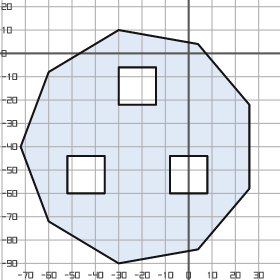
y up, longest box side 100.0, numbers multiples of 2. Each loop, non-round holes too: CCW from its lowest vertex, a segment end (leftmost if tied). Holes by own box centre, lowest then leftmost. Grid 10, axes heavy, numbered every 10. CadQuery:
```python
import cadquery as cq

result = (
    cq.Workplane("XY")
    .moveTo(-30.0, -90.0)
    .lineTo(4.0, -84.0)
    .lineTo(26.0, -58.0)
    .lineTo(26.0, -22.0)
    .lineTo(4.0, 4.0)
    .lineTo(-30.0, 10.0)
    .lineTo(-60.0, -8.0)
    .lineTo(-72.0, -40.0)
    .lineTo(-60.0, -72.0)
    .close()
    .moveTo(-52.0, -60.0)
    .lineTo(-36.0, -60.0)
    .lineTo(-36.0, -44.0)
    .lineTo(-52.0, -44.0)
    .close()
    .moveTo(-8.0, -60.0)
    .lineTo(8.0, -60.0)
    .lineTo(8.0, -44.0)
    .lineTo(-8.0, -44.0)
    .close()
    .moveTo(-30.0, -22.0)
    .lineTo(-14.0, -22.0)
    .lineTo(-14.0, -6.0)
    .lineTo(-30.0, -6.0)
    .close()
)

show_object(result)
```